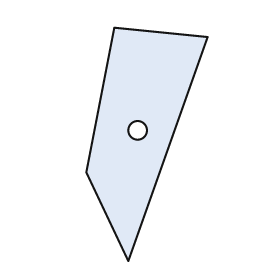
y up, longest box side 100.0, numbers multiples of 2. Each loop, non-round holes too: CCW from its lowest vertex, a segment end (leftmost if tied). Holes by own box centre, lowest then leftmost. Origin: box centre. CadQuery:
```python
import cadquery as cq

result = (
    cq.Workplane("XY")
    .moveTo(-8.0, -50.0)
    .lineTo(26.0, 46.0)
    .lineTo(-14.0, 50.0)
    .lineTo(-26.0, -12.0)
    .close()
    .moveTo(-4.0, 6.0)
    .circle(4.0)
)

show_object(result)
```